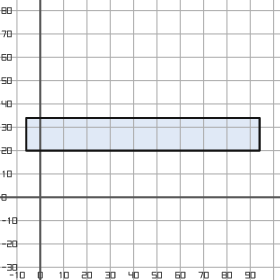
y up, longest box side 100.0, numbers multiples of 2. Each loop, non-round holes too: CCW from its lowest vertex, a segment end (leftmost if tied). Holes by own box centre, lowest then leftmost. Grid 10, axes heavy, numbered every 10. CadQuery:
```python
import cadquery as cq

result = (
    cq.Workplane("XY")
    .moveTo(-6.0, 20.0)
    .lineTo(94.0, 20.0)
    .lineTo(94.0, 34.0)
    .lineTo(-6.0, 34.0)
    .close()
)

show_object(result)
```